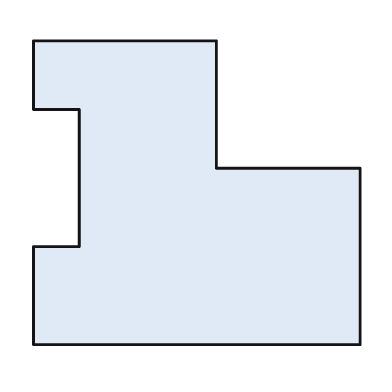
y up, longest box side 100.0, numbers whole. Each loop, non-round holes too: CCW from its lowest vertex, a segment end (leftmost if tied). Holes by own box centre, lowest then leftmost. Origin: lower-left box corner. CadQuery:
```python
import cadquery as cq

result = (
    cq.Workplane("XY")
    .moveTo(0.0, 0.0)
    .lineTo(100.0, 0.0)
    .lineTo(100.0, 54.0)
    .lineTo(56.0, 54.0)
    .lineTo(56.0, 93.0)
    .lineTo(0.0, 93.0)
    .lineTo(0.0, 72.0)
    .lineTo(14.0, 72.0)
    .lineTo(14.0, 30.0)
    .lineTo(0.0, 30.0)
    .close()
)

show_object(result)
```